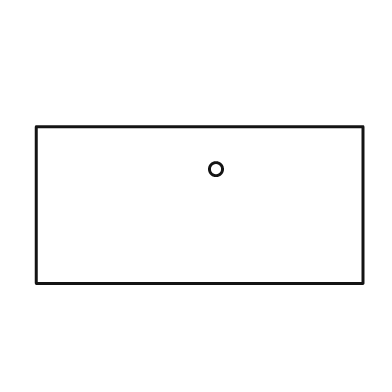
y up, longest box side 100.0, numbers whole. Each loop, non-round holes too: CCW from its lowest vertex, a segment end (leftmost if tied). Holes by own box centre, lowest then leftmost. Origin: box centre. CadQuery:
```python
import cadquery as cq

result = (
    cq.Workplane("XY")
    .moveTo(-50.0, -24.0)
    .lineTo(50.0, -24.0)
    .lineTo(50.0, 24.0)
    .lineTo(-50.0, 24.0)
    .close()
    .moveTo(5.0, 11.0)
    .circle(2.0)
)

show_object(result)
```